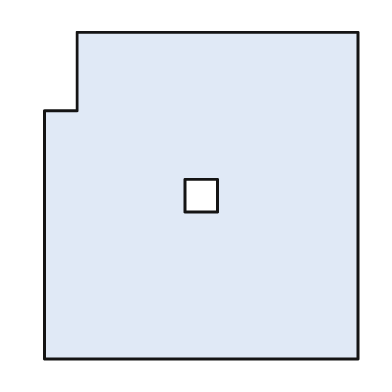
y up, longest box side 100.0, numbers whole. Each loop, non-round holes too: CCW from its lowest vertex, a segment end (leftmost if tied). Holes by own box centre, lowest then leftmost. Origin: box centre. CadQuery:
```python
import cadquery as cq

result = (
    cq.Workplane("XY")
    .moveTo(-48.0, -50.0)
    .lineTo(48.0, -50.0)
    .lineTo(48.0, 50.0)
    .lineTo(-38.0, 50.0)
    .lineTo(-38.0, 26.0)
    .lineTo(-48.0, 26.0)
    .close()
    .moveTo(-5.0, -5.0)
    .lineTo(5.0, -5.0)
    .lineTo(5.0, 5.0)
    .lineTo(-5.0, 5.0)
    .close()
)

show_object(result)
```